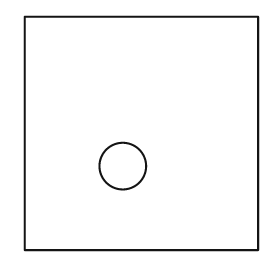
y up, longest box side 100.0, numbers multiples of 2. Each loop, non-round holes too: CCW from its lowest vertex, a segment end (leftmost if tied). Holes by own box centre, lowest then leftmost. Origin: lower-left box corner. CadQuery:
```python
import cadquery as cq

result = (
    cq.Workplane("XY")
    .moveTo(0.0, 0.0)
    .lineTo(100.0, 0.0)
    .lineTo(100.0, 100.0)
    .lineTo(0.0, 100.0)
    .close()
    .moveTo(42.0, 36.0)
    .circle(10.0)
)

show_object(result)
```